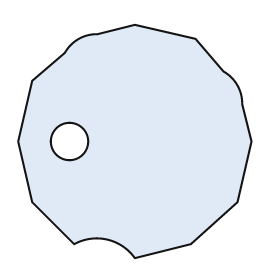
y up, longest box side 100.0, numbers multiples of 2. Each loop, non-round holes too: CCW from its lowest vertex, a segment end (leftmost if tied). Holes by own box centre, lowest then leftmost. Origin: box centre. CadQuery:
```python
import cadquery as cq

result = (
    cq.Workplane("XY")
    .moveTo(0.0, -50.0)
    .lineTo(24.0, -44.0)
    .lineTo(44.0, -26.0)
    .lineTo(50.0, 0.0)
    .lineTo(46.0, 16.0)
    .threePointArc((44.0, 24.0), (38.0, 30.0))
    .lineTo(26.0, 44.0)
    .lineTo(0.0, 50.0)
    .lineTo(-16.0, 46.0)
    .threePointArc((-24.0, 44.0), (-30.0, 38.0))
    .lineTo(-44.0, 26.0)
    .lineTo(-50.0, 0.0)
    .lineTo(-44.0, -26.0)
    .lineTo(-26.0, -44.0)
    .threePointArc((-12.0, -42.0), (0.0, -50.0))
    .close()
    .moveTo(-28.0, 0.0)
    .circle(8.0)
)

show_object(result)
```